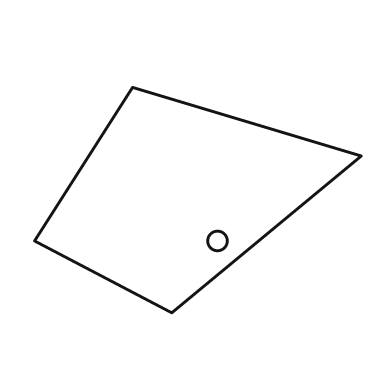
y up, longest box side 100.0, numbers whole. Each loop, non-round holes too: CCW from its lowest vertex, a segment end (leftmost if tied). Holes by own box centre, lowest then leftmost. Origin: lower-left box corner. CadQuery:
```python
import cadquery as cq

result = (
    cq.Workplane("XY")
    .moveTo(42.0, 0.0)
    .lineTo(100.0, 48.0)
    .lineTo(30.0, 69.0)
    .lineTo(0.0, 22.0)
    .close()
    .moveTo(56.0, 22.0)
    .circle(3.0)
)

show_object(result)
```